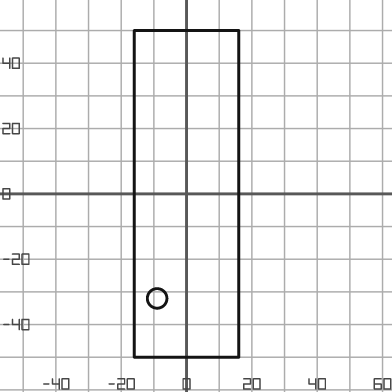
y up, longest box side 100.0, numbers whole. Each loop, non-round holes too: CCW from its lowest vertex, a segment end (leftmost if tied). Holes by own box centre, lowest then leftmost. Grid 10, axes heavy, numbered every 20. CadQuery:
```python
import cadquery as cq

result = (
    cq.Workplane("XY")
    .moveTo(-16.0, -50.0)
    .lineTo(16.0, -50.0)
    .lineTo(16.0, 50.0)
    .lineTo(-16.0, 50.0)
    .close()
    .moveTo(-9.0, -32.0)
    .circle(3.0)
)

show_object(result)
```